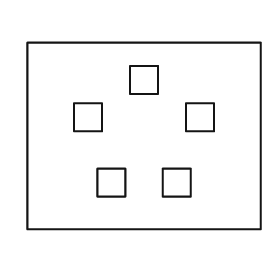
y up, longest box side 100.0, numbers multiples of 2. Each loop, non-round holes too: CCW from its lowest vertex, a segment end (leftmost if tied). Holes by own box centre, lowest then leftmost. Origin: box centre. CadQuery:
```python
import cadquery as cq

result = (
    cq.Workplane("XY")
    .moveTo(-50.0, -40.0)
    .lineTo(50.0, -40.0)
    .lineTo(50.0, 40.0)
    .lineTo(-50.0, 40.0)
    .close()
    .moveTo(-20.0, -26.0)
    .lineTo(-8.0, -26.0)
    .lineTo(-8.0, -14.0)
    .lineTo(-20.0, -14.0)
    .close()
    .moveTo(8.0, -26.0)
    .lineTo(20.0, -26.0)
    .lineTo(20.0, -14.0)
    .lineTo(8.0, -14.0)
    .close()
    .moveTo(-30.0, 2.0)
    .lineTo(-18.0, 2.0)
    .lineTo(-18.0, 14.0)
    .lineTo(-30.0, 14.0)
    .close()
    .moveTo(18.0, 2.0)
    .lineTo(30.0, 2.0)
    .lineTo(30.0, 14.0)
    .lineTo(18.0, 14.0)
    .close()
    .moveTo(-6.0, 18.0)
    .lineTo(6.0, 18.0)
    .lineTo(6.0, 30.0)
    .lineTo(-6.0, 30.0)
    .close()
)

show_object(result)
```